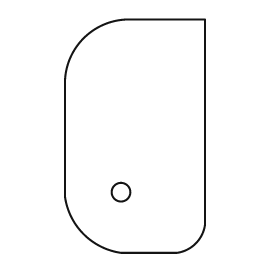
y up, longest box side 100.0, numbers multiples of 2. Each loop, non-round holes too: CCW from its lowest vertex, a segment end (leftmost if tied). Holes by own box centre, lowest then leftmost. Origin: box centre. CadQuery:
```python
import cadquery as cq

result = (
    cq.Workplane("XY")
    .moveTo(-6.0, -50.0)
    .lineTo(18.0, -50.0)
    .threePointArc((26.0, -46.0), (30.0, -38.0))
    .lineTo(30.0, 50.0)
    .lineTo(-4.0, 50.0)
    .threePointArc((-22.0, 42.0), (-30.0, 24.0))
    .lineTo(-30.0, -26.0)
    .threePointArc((-22.0, -42.0), (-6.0, -50.0))
    .close()
    .moveTo(-6.0, -24.0)
    .circle(4.0)
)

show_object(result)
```